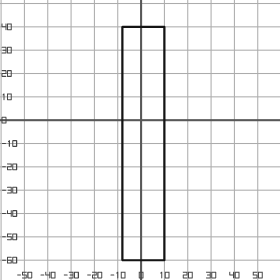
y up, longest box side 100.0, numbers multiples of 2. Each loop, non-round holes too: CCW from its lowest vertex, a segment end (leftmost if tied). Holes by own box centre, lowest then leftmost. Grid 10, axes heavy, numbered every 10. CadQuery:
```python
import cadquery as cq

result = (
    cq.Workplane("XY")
    .moveTo(-8.0, -60.0)
    .lineTo(10.0, -60.0)
    .lineTo(10.0, 40.0)
    .lineTo(-8.0, 40.0)
    .close()
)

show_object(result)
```